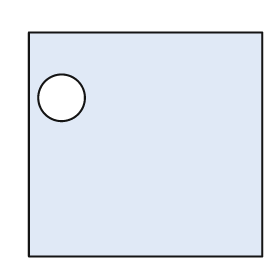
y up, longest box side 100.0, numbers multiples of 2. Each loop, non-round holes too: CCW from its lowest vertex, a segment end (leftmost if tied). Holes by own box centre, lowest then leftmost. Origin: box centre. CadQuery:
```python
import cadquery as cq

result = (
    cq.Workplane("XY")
    .moveTo(-50.0, -48.0)
    .lineTo(50.0, -48.0)
    .lineTo(50.0, 48.0)
    .lineTo(-50.0, 48.0)
    .close()
    .moveTo(-36.0, 20.0)
    .circle(10.0)
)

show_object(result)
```